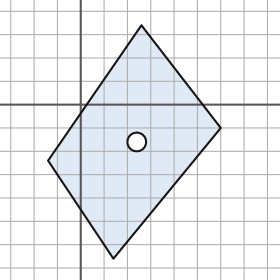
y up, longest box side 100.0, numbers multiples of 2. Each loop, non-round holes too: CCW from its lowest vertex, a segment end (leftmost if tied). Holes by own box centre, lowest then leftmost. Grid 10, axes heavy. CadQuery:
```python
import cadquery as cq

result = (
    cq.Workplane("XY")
    .moveTo(14.0, -66.0)
    .lineTo(60.0, -10.0)
    .lineTo(26.0, 34.0)
    .lineTo(-14.0, -24.0)
    .close()
    .moveTo(24.0, -16.0)
    .circle(4.0)
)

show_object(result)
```